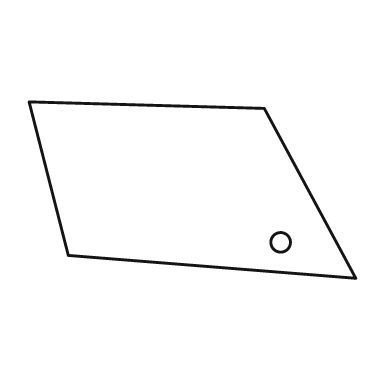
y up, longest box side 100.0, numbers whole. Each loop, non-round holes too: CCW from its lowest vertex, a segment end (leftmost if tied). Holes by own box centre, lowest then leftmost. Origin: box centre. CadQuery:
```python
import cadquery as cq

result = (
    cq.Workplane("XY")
    .moveTo(50.0, -27.0)
    .lineTo(22.0, 25.0)
    .lineTo(-50.0, 27.0)
    .lineTo(-38.0, -20.0)
    .close()
    .moveTo(27.0, -16.0)
    .circle(3.0)
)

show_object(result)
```